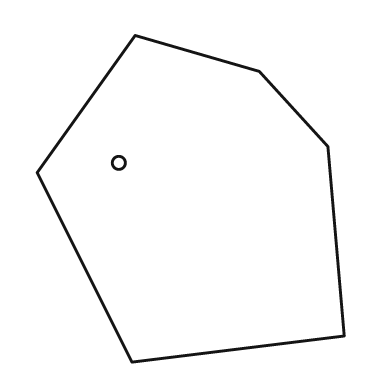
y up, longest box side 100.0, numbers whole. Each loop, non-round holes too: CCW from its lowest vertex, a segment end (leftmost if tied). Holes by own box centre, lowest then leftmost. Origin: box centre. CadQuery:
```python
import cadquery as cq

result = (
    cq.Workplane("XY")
    .moveTo(-18.0, -50.0)
    .lineTo(47.0, -42.0)
    .lineTo(42.0, 16.0)
    .lineTo(21.0, 39.0)
    .lineTo(-17.0, 50.0)
    .lineTo(-47.0, 8.0)
    .close()
    .moveTo(-22.0, 11.0)
    .circle(2.0)
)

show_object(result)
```